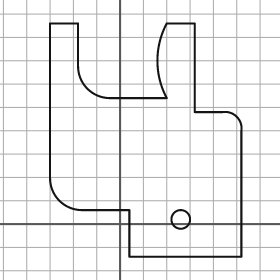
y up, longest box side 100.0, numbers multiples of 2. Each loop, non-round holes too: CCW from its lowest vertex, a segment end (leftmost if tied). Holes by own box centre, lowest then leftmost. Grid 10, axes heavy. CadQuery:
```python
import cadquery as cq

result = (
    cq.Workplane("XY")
    .moveTo(4.0, -14.0)
    .lineTo(52.0, -14.0)
    .lineTo(52.0, 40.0)
    .threePointArc((50.0, 46.0), (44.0, 48.0))
    .lineTo(32.0, 48.0)
    .lineTo(32.0, 86.0)
    .lineTo(20.0, 86.0)
    .threePointArc((16.0, 70.0), (20.0, 54.0))
    .lineTo(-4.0, 54.0)
    .threePointArc((-14.0, 58.0), (-18.0, 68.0))
    .lineTo(-18.0, 86.0)
    .lineTo(-30.0, 86.0)
    .lineTo(-30.0, 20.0)
    .threePointArc((-26.0, 10.0), (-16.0, 6.0))
    .lineTo(4.0, 6.0)
    .close()
    .moveTo(26.0, 2.0)
    .circle(4.0)
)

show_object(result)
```